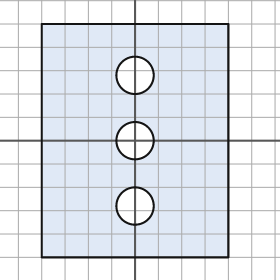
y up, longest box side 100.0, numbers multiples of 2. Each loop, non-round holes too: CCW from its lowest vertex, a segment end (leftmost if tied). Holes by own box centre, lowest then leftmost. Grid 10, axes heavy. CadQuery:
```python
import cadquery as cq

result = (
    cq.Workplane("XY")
    .moveTo(-40.0, -50.0)
    .lineTo(40.0, -50.0)
    .lineTo(40.0, 50.0)
    .lineTo(-40.0, 50.0)
    .close()
    .moveTo(0.0, -28.0)
    .circle(8.0)
    .moveTo(0.0, 0.0)
    .circle(8.0)
    .moveTo(0.0, 28.0)
    .circle(8.0)
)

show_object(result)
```